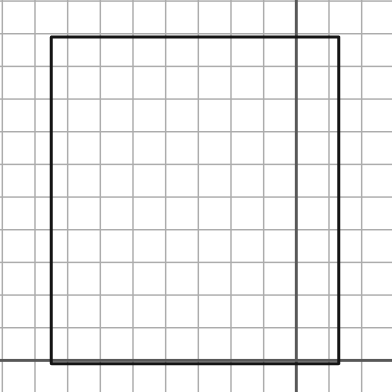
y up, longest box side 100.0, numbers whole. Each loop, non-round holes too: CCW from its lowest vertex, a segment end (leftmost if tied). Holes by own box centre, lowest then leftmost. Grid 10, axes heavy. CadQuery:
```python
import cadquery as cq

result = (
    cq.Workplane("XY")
    .moveTo(-75.0, -1.0)
    .lineTo(13.0, -1.0)
    .lineTo(13.0, 99.0)
    .lineTo(-75.0, 99.0)
    .close()
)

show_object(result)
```